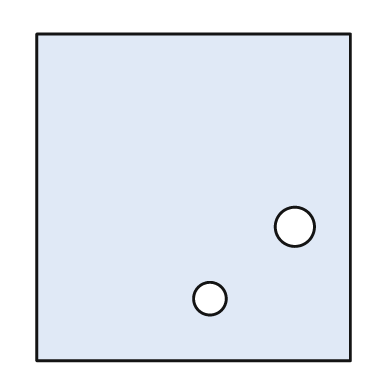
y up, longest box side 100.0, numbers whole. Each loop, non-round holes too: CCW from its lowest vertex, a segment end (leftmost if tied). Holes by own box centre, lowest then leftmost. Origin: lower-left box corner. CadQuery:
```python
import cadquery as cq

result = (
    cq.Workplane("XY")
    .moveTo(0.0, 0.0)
    .lineTo(96.0, 0.0)
    .lineTo(96.0, 100.0)
    .lineTo(0.0, 100.0)
    .close()
    .moveTo(53.0, 19.0)
    .circle(5.0)
    .moveTo(79.0, 41.0)
    .circle(6.0)
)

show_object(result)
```